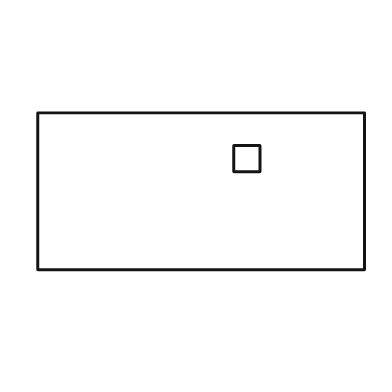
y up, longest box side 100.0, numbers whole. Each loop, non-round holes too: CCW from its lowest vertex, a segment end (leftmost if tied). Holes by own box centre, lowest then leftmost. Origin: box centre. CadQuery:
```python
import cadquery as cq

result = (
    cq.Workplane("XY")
    .moveTo(-50.0, -24.0)
    .lineTo(50.0, -24.0)
    .lineTo(50.0, 24.0)
    .lineTo(-50.0, 24.0)
    .close()
    .moveTo(10.0, 6.0)
    .lineTo(18.0, 6.0)
    .lineTo(18.0, 14.0)
    .lineTo(10.0, 14.0)
    .close()
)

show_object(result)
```